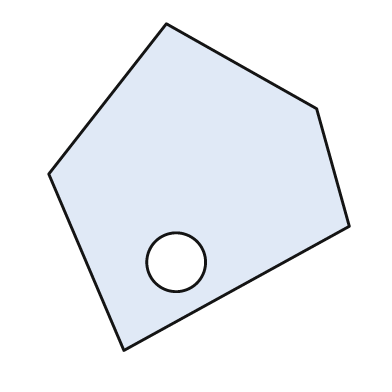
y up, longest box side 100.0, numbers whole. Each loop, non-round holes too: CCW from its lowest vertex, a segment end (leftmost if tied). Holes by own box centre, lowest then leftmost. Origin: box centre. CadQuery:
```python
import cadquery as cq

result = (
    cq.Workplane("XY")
    .moveTo(-23.0, -50.0)
    .lineTo(46.0, -12.0)
    .lineTo(36.0, 24.0)
    .lineTo(-10.0, 50.0)
    .lineTo(-46.0, 4.0)
    .close()
    .moveTo(-7.0, -23.0)
    .circle(9.0)
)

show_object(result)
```